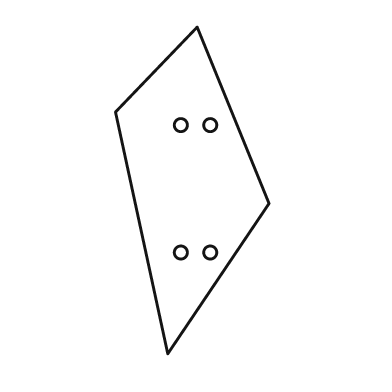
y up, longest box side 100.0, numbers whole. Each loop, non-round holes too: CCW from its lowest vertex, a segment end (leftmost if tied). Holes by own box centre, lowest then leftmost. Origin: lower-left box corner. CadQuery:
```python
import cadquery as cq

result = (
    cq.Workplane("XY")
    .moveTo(16.0, 0.0)
    .lineTo(47.0, 46.0)
    .lineTo(25.0, 100.0)
    .lineTo(0.0, 74.0)
    .close()
    .moveTo(20.0, 31.0)
    .circle(2.0)
    .moveTo(29.0, 31.0)
    .circle(2.0)
    .moveTo(20.0, 70.0)
    .circle(2.0)
    .moveTo(29.0, 70.0)
    .circle(2.0)
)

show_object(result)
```